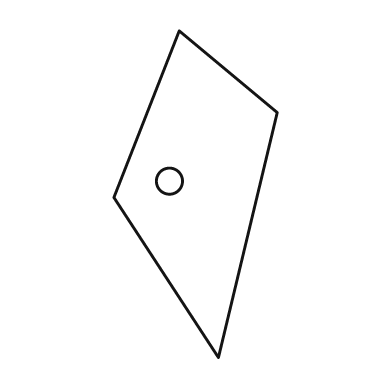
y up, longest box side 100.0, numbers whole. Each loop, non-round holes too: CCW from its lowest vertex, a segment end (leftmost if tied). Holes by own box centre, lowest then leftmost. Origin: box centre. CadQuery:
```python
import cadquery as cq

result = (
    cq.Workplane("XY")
    .moveTo(7.0, -50.0)
    .lineTo(25.0, 25.0)
    .lineTo(-5.0, 50.0)
    .lineTo(-25.0, -1.0)
    .close()
    .moveTo(-8.0, 4.0)
    .circle(4.0)
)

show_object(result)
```